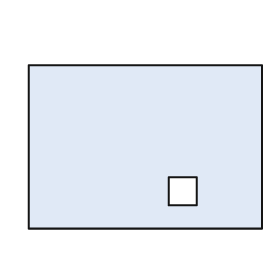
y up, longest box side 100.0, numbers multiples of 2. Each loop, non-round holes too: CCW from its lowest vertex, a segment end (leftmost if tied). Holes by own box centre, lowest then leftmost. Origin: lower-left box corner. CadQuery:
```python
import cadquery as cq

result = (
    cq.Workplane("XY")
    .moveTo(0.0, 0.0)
    .lineTo(100.0, 0.0)
    .lineTo(100.0, 70.0)
    .lineTo(0.0, 70.0)
    .close()
    .moveTo(60.0, 10.0)
    .lineTo(72.0, 10.0)
    .lineTo(72.0, 22.0)
    .lineTo(60.0, 22.0)
    .close()
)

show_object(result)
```